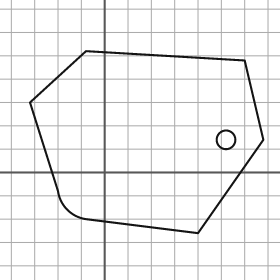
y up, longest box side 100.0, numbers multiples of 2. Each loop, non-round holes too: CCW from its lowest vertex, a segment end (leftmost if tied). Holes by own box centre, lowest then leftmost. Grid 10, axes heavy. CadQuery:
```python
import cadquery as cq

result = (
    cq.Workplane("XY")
    .moveTo(40.0, -26.0)
    .lineTo(68.0, 14.0)
    .lineTo(60.0, 48.0)
    .lineTo(-8.0, 52.0)
    .lineTo(-32.0, 30.0)
    .lineTo(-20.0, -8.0)
    .threePointArc((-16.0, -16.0), (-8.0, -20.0))
    .close()
    .moveTo(52.0, 14.0)
    .circle(4.0)
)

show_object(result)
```